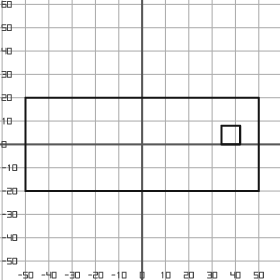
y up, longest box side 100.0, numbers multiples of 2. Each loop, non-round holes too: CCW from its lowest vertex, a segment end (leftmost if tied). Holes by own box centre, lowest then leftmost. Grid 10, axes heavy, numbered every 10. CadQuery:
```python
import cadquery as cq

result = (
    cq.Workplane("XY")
    .moveTo(-50.0, -20.0)
    .lineTo(50.0, -20.0)
    .lineTo(50.0, 20.0)
    .lineTo(-50.0, 20.0)
    .close()
    .moveTo(34.0, 0.0)
    .lineTo(42.0, 0.0)
    .lineTo(42.0, 8.0)
    .lineTo(34.0, 8.0)
    .close()
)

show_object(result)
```